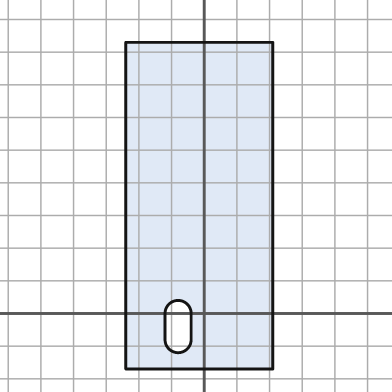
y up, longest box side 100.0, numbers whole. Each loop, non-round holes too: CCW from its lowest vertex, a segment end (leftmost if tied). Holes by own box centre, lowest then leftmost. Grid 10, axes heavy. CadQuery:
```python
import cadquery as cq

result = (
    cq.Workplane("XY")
    .moveTo(-24.0, -17.0)
    .lineTo(21.0, -17.0)
    .lineTo(21.0, 83.0)
    .lineTo(-24.0, 83.0)
    .close()
    .moveTo(-12.0, -8.0)
    .threePointArc((-8.0, -12.0), (-4.0, -8.0))
    .lineTo(-4.0, 0.0)
    .threePointArc((-8.0, 4.0), (-12.0, 0.0))
    .close()
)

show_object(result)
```